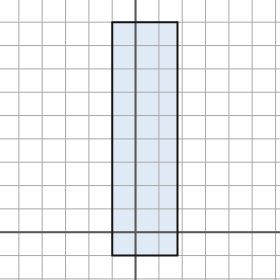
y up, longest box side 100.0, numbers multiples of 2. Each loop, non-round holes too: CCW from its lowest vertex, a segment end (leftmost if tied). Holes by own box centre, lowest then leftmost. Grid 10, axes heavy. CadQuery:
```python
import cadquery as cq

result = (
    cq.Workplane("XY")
    .moveTo(-10.0, -10.0)
    .lineTo(18.0, -10.0)
    .lineTo(18.0, 90.0)
    .lineTo(-10.0, 90.0)
    .close()
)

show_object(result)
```